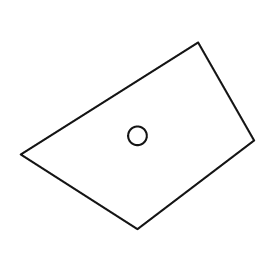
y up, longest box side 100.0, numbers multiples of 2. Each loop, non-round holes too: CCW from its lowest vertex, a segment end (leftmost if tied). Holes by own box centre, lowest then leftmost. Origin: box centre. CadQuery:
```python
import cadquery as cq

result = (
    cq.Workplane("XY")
    .moveTo(0.0, -40.0)
    .lineTo(50.0, -2.0)
    .lineTo(26.0, 40.0)
    .lineTo(-50.0, -8.0)
    .close()
    .moveTo(0.0, 0.0)
    .circle(4.0)
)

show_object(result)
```